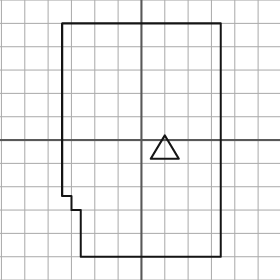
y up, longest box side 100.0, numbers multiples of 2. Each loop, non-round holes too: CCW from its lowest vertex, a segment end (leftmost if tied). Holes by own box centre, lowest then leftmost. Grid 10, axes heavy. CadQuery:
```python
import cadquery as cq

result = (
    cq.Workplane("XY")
    .moveTo(-26.0, -50.0)
    .lineTo(34.0, -50.0)
    .lineTo(34.0, 50.0)
    .lineTo(-34.0, 50.0)
    .lineTo(-34.0, -24.0)
    .lineTo(-30.0, -24.0)
    .lineTo(-30.0, -30.0)
    .lineTo(-26.0, -30.0)
    .close()
    .moveTo(4.0, -8.0)
    .lineTo(16.0, -8.0)
    .lineTo(10.0, 2.0)
    .close()
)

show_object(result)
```